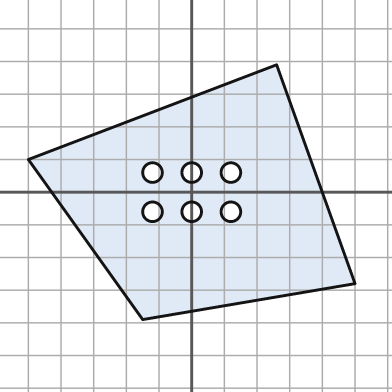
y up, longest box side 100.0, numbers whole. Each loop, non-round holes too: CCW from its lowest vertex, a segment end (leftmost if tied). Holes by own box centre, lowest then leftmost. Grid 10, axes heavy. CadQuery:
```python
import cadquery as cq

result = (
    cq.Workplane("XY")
    .moveTo(-15.0, -39.0)
    .lineTo(50.0, -28.0)
    .lineTo(26.0, 39.0)
    .lineTo(-50.0, 10.0)
    .close()
    .moveTo(-12.0, -6.0)
    .circle(3.0)
    .moveTo(0.0, -6.0)
    .circle(3.0)
    .moveTo(12.0, -6.0)
    .circle(3.0)
    .moveTo(-12.0, 6.0)
    .circle(3.0)
    .moveTo(0.0, 6.0)
    .circle(3.0)
    .moveTo(12.0, 6.0)
    .circle(3.0)
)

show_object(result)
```